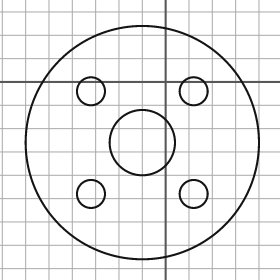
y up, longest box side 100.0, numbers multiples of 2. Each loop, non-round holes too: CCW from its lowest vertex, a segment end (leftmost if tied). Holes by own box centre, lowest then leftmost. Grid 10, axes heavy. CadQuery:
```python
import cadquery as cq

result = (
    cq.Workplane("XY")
    .moveTo(-10.0, -26.0)
    .circle(50.0)
    .moveTo(-32.0, -48.0)
    .circle(6.0)
    .moveTo(12.0, -48.0)
    .circle(6.0)
    .moveTo(-10.0, -26.0)
    .circle(14.0)
    .moveTo(-32.0, -4.0)
    .circle(6.0)
    .moveTo(12.0, -4.0)
    .circle(6.0)
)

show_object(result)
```